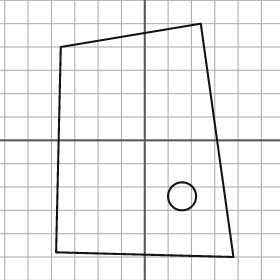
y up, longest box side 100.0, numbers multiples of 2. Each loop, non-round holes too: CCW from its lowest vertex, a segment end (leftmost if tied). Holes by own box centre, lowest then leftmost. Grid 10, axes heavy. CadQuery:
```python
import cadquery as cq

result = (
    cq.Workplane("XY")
    .moveTo(38.0, -50.0)
    .lineTo(24.0, 50.0)
    .lineTo(-36.0, 40.0)
    .lineTo(-38.0, -48.0)
    .close()
    .moveTo(16.0, -24.0)
    .circle(6.0)
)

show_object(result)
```